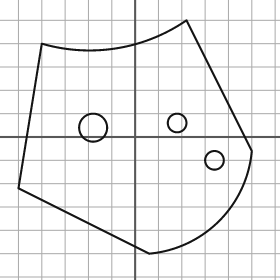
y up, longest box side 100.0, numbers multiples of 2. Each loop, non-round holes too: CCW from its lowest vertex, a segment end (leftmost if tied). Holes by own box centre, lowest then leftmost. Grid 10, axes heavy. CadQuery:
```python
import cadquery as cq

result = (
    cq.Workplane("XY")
    .moveTo(6.0, -50.0)
    .threePointArc((36.0, -36.0), (50.0, -6.0))
    .lineTo(22.0, 50.0)
    .threePointArc((-8.0, 38.0), (-40.0, 40.0))
    .lineTo(-50.0, -22.0)
    .close()
    .moveTo(34.0, -10.0)
    .circle(4.0)
    .moveTo(-18.0, 4.0)
    .circle(6.0)
    .moveTo(18.0, 6.0)
    .circle(4.0)
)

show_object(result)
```